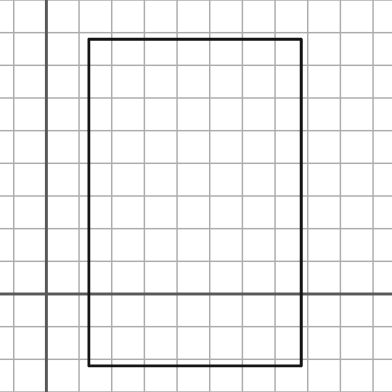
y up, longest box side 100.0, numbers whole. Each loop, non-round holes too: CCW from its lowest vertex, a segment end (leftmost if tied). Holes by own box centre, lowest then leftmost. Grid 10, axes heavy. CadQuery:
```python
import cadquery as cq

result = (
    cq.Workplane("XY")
    .moveTo(13.0, -22.0)
    .lineTo(78.0, -22.0)
    .lineTo(78.0, 78.0)
    .lineTo(13.0, 78.0)
    .close()
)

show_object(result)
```